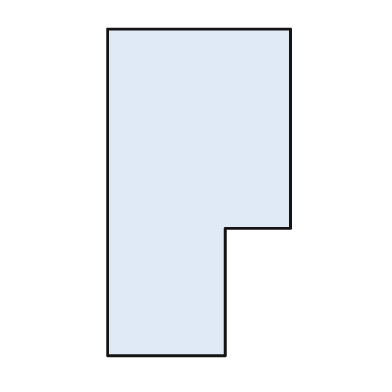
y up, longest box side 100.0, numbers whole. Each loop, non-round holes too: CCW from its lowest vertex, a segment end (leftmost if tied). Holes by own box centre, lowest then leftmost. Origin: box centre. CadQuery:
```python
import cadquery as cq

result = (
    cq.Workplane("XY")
    .moveTo(-28.0, -50.0)
    .lineTo(8.0, -50.0)
    .lineTo(8.0, -11.0)
    .lineTo(28.0, -11.0)
    .lineTo(28.0, 50.0)
    .lineTo(-28.0, 50.0)
    .close()
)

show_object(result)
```